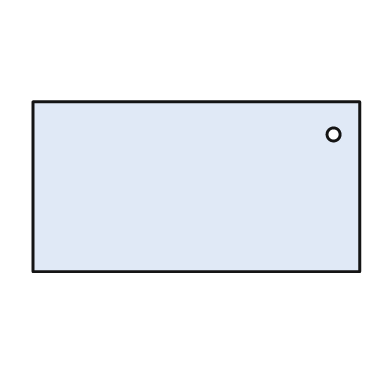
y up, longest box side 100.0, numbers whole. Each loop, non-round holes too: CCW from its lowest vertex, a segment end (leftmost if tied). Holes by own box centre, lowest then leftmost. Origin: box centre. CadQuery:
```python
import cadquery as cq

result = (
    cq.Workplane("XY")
    .moveTo(-50.0, -26.0)
    .lineTo(50.0, -26.0)
    .lineTo(50.0, 26.0)
    .lineTo(-50.0, 26.0)
    .close()
    .moveTo(42.0, 16.0)
    .circle(2.0)
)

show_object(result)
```